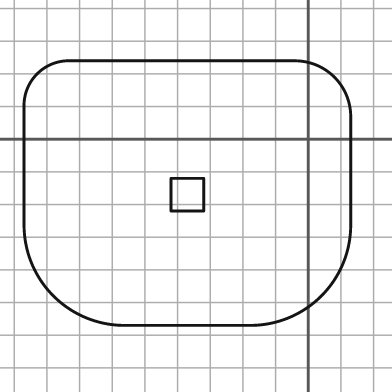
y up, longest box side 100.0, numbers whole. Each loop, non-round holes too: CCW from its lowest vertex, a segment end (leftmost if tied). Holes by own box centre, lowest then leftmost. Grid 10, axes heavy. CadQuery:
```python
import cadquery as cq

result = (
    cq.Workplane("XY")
    .moveTo(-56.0, -57.0)
    .lineTo(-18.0, -57.0)
    .threePointArc((4.0, -48.0), (13.0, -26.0))
    .lineTo(13.0, 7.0)
    .threePointArc((8.0, 19.0), (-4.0, 24.0))
    .lineTo(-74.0, 24.0)
    .threePointArc((-83.0, 20.0), (-87.0, 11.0))
    .lineTo(-87.0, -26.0)
    .threePointArc((-78.0, -48.0), (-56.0, -57.0))
    .close()
    .moveTo(-42.0, -22.0)
    .lineTo(-32.0, -22.0)
    .lineTo(-32.0, -12.0)
    .lineTo(-42.0, -12.0)
    .close()
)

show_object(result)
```